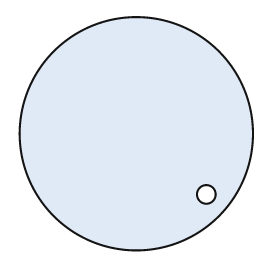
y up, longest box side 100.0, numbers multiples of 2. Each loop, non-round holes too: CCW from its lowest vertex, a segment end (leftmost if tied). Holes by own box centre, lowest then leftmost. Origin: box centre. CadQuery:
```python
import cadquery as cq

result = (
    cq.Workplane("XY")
    .moveTo(0.0, 0.0)
    .circle(50.0)
    .moveTo(30.0, -26.0)
    .circle(4.0)
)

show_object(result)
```